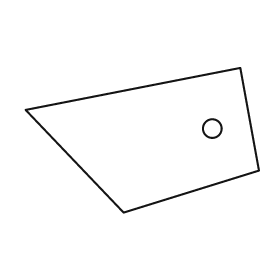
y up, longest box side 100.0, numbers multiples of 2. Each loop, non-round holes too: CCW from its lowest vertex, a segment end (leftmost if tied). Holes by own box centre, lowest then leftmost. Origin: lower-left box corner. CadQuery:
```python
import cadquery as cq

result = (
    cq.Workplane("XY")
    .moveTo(42.0, 0.0)
    .lineTo(100.0, 18.0)
    .lineTo(92.0, 62.0)
    .lineTo(0.0, 44.0)
    .close()
    .moveTo(80.0, 36.0)
    .circle(4.0)
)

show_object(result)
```